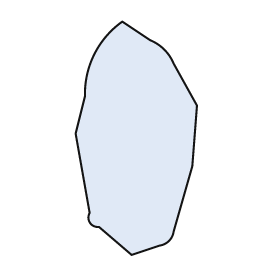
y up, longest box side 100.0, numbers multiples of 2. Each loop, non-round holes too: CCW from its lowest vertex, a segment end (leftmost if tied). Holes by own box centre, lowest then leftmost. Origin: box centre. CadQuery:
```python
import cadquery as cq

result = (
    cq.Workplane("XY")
    .moveTo(-2.0, -50.0)
    .lineTo(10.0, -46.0)
    .threePointArc((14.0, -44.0), (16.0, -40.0))
    .lineTo(24.0, -12.0)
    .lineTo(26.0, 14.0)
    .lineTo(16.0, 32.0)
    .threePointArc((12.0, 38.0), (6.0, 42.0))
    .lineTo(-6.0, 50.0)
    .threePointArc((-18.0, 36.0), (-22.0, 18.0))
    .lineTo(-26.0, 2.0)
    .lineTo(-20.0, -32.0)
    .threePointArc((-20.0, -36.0), (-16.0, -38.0))
    .close()
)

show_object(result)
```